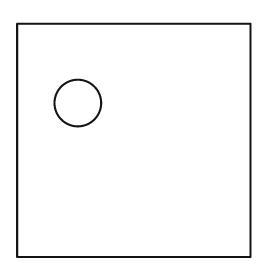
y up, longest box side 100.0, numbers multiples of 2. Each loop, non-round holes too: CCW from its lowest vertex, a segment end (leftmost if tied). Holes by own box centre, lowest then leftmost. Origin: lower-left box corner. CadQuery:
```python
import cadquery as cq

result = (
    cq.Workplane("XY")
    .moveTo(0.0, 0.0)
    .lineTo(100.0, 0.0)
    .lineTo(100.0, 100.0)
    .lineTo(0.0, 100.0)
    .close()
    .moveTo(26.0, 66.0)
    .circle(10.0)
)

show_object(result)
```